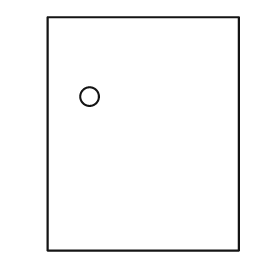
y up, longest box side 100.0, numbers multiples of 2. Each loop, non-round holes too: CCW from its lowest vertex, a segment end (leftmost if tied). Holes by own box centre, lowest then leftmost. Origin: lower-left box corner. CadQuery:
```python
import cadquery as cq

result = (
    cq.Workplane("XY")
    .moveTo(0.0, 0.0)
    .lineTo(82.0, 0.0)
    .lineTo(82.0, 100.0)
    .lineTo(0.0, 100.0)
    .close()
    .moveTo(18.0, 66.0)
    .circle(4.0)
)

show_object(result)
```